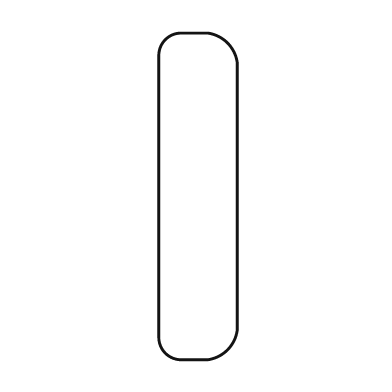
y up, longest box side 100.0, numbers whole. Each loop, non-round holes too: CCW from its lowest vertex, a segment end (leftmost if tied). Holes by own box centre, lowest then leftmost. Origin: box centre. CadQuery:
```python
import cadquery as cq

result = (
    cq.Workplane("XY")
    .moveTo(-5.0, -50.0)
    .lineTo(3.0, -50.0)
    .threePointArc((9.0, -47.0), (12.0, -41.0))
    .lineTo(12.0, 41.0)
    .threePointArc((9.0, 47.0), (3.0, 50.0))
    .lineTo(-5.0, 50.0)
    .threePointArc((-10.0, 48.0), (-12.0, 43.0))
    .lineTo(-12.0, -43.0)
    .threePointArc((-10.0, -48.0), (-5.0, -50.0))
    .close()
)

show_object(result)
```